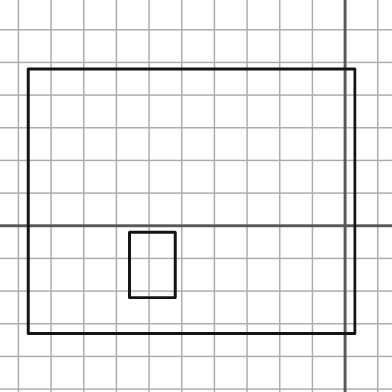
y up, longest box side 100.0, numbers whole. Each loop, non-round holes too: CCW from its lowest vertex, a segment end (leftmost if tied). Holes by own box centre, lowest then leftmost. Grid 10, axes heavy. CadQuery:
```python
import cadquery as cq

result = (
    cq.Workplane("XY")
    .moveTo(-97.0, -33.0)
    .lineTo(3.0, -33.0)
    .lineTo(3.0, 48.0)
    .lineTo(-97.0, 48.0)
    .close()
    .moveTo(-66.0, -22.0)
    .lineTo(-52.0, -22.0)
    .lineTo(-52.0, -2.0)
    .lineTo(-66.0, -2.0)
    .close()
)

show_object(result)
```